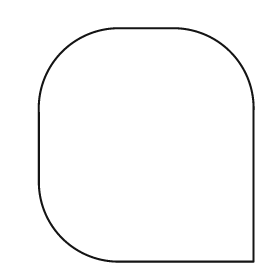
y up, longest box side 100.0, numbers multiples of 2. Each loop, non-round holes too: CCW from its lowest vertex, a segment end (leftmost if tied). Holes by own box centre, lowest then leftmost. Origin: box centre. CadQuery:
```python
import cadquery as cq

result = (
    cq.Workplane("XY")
    .moveTo(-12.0, -50.0)
    .lineTo(46.0, -50.0)
    .lineTo(46.0, 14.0)
    .threePointArc((36.0, 40.0), (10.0, 50.0))
    .lineTo(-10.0, 50.0)
    .threePointArc((-36.0, 40.0), (-46.0, 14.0))
    .lineTo(-46.0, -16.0)
    .threePointArc((-36.0, -40.0), (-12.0, -50.0))
    .close()
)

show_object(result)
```